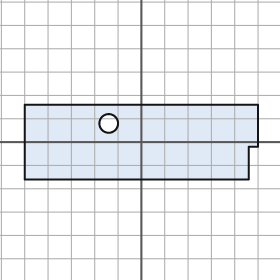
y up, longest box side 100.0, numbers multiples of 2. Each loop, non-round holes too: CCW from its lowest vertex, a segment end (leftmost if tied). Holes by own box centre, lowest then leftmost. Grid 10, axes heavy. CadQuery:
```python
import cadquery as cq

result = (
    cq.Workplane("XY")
    .moveTo(-50.0, -16.0)
    .lineTo(46.0, -16.0)
    .lineTo(46.0, -2.0)
    .lineTo(50.0, -2.0)
    .lineTo(50.0, 16.0)
    .lineTo(-50.0, 16.0)
    .close()
    .moveTo(-14.0, 8.0)
    .circle(4.0)
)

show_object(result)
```